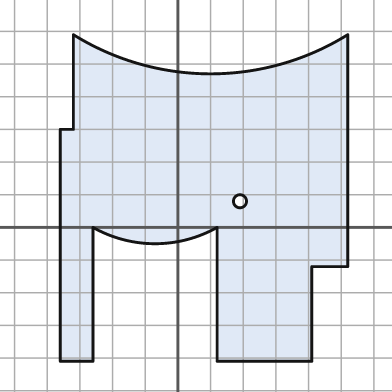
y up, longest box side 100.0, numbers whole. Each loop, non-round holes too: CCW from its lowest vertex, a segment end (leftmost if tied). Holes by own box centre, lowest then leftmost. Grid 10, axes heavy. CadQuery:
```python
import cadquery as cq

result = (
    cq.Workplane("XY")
    .moveTo(-36.0, -41.0)
    .lineTo(-26.0, -41.0)
    .lineTo(-26.0, 0.0)
    .threePointArc((-7.0, -5.0), (12.0, 0.0))
    .lineTo(12.0, -41.0)
    .lineTo(41.0, -41.0)
    .lineTo(41.0, -12.0)
    .lineTo(52.0, -12.0)
    .lineTo(52.0, 59.0)
    .threePointArc((10.0, 47.0), (-32.0, 59.0))
    .lineTo(-32.0, 30.0)
    .lineTo(-36.0, 30.0)
    .close()
    .moveTo(19.0, 8.0)
    .circle(2.0)
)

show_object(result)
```